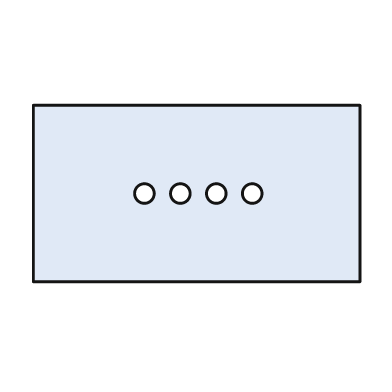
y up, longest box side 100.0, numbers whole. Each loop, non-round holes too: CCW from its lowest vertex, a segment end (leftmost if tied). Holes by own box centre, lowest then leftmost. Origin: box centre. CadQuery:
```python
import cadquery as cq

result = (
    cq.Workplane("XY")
    .moveTo(-50.0, -27.0)
    .lineTo(50.0, -27.0)
    .lineTo(50.0, 27.0)
    .lineTo(-50.0, 27.0)
    .close()
    .moveTo(-16.0, 0.0)
    .circle(3.0)
    .moveTo(-5.0, 0.0)
    .circle(3.0)
    .moveTo(6.0, 0.0)
    .circle(3.0)
    .moveTo(17.0, 0.0)
    .circle(3.0)
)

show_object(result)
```